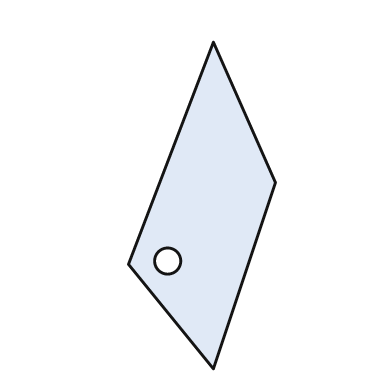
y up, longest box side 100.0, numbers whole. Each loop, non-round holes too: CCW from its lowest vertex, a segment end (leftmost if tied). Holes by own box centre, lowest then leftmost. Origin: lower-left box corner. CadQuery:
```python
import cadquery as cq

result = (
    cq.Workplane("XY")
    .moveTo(26.0, 0.0)
    .lineTo(45.0, 57.0)
    .lineTo(26.0, 100.0)
    .lineTo(0.0, 32.0)
    .close()
    .moveTo(12.0, 33.0)
    .circle(4.0)
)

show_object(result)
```